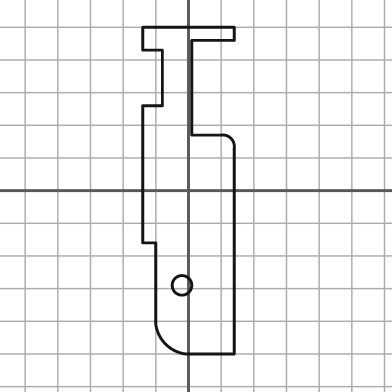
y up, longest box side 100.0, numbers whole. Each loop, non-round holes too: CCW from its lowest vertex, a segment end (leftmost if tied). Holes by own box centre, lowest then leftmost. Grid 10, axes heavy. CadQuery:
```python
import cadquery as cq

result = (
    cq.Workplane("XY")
    .moveTo(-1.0, -50.0)
    .lineTo(14.0, -50.0)
    .lineTo(14.0, 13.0)
    .threePointArc((13.0, 16.0), (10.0, 17.0))
    .lineTo(1.0, 17.0)
    .lineTo(1.0, 46.0)
    .lineTo(14.0, 46.0)
    .lineTo(14.0, 50.0)
    .lineTo(-14.0, 50.0)
    .lineTo(-14.0, 43.0)
    .lineTo(-8.0, 43.0)
    .lineTo(-8.0, 26.0)
    .lineTo(-14.0, 26.0)
    .lineTo(-14.0, -16.0)
    .lineTo(-10.0, -16.0)
    .lineTo(-10.0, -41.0)
    .threePointArc((-7.0, -47.0), (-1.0, -50.0))
    .close()
    .moveTo(-2.0, -29.0)
    .circle(3.0)
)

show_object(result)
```